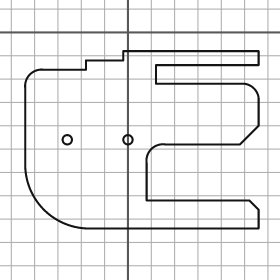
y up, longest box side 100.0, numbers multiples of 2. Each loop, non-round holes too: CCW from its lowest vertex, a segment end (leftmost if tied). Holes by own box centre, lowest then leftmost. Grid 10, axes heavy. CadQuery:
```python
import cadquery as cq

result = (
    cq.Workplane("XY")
    .moveTo(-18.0, -84.0)
    .lineTo(56.0, -84.0)
    .lineTo(56.0, -76.0)
    .lineTo(52.0, -72.0)
    .lineTo(8.0, -72.0)
    .lineTo(8.0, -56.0)
    .threePointArc((10.0, -50.0), (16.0, -48.0))
    .lineTo(48.0, -48.0)
    .lineTo(56.0, -40.0)
    .lineTo(56.0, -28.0)
    .threePointArc((54.0, -24.0), (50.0, -22.0))
    .lineTo(12.0, -22.0)
    .lineTo(12.0, -14.0)
    .lineTo(56.0, -14.0)
    .lineTo(56.0, -8.0)
    .lineTo(-2.0, -8.0)
    .lineTo(-2.0, -12.0)
    .lineTo(-18.0, -12.0)
    .lineTo(-18.0, -16.0)
    .lineTo(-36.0, -16.0)
    .threePointArc((-42.0, -18.0), (-44.0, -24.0))
    .lineTo(-44.0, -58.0)
    .threePointArc((-36.0, -76.0), (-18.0, -84.0))
    .close()
    .moveTo(-26.0, -46.0)
    .circle(2.0)
    .moveTo(0.0, -46.0)
    .circle(2.0)
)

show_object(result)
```